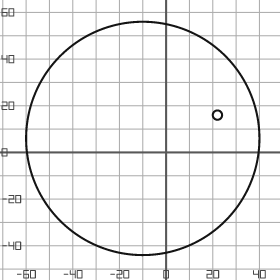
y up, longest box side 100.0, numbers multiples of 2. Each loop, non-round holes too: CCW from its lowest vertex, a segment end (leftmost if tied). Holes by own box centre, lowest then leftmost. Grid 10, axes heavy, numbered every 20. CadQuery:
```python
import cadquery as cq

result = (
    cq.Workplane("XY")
    .moveTo(-10.0, 6.0)
    .circle(50.0)
    .moveTo(22.0, 16.0)
    .circle(2.0)
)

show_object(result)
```